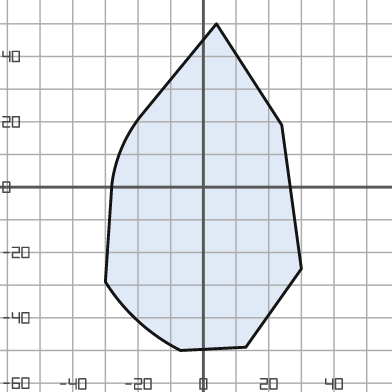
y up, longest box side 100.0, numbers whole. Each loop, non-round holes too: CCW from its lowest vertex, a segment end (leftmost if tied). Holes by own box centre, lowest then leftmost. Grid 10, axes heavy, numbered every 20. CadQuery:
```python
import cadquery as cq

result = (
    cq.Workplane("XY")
    .moveTo(-7.0, -50.0)
    .lineTo(13.0, -49.0)
    .lineTo(30.0, -25.0)
    .lineTo(24.0, 19.0)
    .lineTo(4.0, 50.0)
    .lineTo(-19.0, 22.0)
    .threePointArc((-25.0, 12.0), (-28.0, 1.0))
    .lineTo(-30.0, -29.0)
    .threePointArc((-20.0, -41.0), (-7.0, -50.0))
    .close()
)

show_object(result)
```